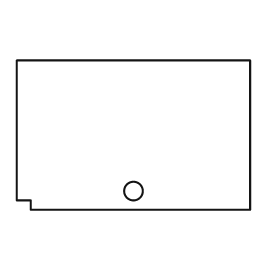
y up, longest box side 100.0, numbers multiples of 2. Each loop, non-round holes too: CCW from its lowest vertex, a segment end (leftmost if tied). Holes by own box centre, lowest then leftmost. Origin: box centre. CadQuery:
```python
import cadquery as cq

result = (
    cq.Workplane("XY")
    .moveTo(-44.0, -32.0)
    .lineTo(50.0, -32.0)
    .lineTo(50.0, 32.0)
    .lineTo(-50.0, 32.0)
    .lineTo(-50.0, -28.0)
    .lineTo(-44.0, -28.0)
    .close()
    .moveTo(0.0, -24.0)
    .circle(4.0)
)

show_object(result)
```